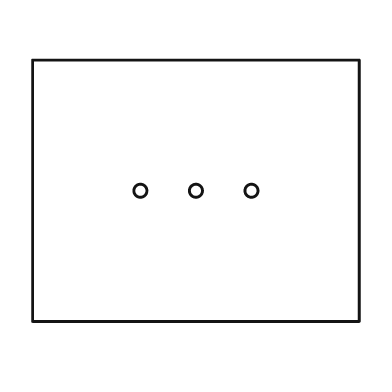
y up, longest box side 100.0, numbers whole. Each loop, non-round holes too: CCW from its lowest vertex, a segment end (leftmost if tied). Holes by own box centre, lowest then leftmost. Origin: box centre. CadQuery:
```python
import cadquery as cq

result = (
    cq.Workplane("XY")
    .moveTo(-50.0, -40.0)
    .lineTo(50.0, -40.0)
    .lineTo(50.0, 40.0)
    .lineTo(-50.0, 40.0)
    .close()
    .moveTo(-17.0, 0.0)
    .circle(2.0)
    .moveTo(0.0, 0.0)
    .circle(2.0)
    .moveTo(17.0, 0.0)
    .circle(2.0)
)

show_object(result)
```